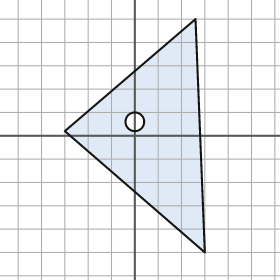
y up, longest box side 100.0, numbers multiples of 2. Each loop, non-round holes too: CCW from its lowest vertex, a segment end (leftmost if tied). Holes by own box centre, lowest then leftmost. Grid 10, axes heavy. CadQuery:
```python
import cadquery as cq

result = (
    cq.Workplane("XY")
    .moveTo(30.0, -50.0)
    .lineTo(26.0, 50.0)
    .lineTo(-30.0, 2.0)
    .close()
    .moveTo(0.0, 6.0)
    .circle(4.0)
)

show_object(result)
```